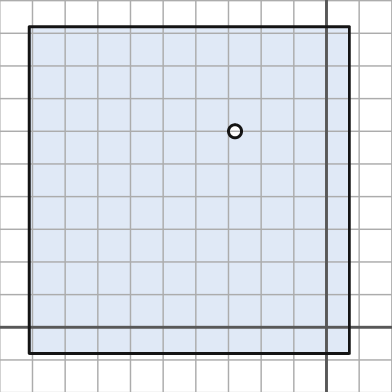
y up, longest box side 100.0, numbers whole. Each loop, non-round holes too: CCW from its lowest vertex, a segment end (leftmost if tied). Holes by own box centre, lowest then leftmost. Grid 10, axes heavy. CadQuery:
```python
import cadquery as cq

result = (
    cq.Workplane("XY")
    .moveTo(-91.0, -8.0)
    .lineTo(7.0, -8.0)
    .lineTo(7.0, 92.0)
    .lineTo(-91.0, 92.0)
    .close()
    .moveTo(-28.0, 60.0)
    .circle(2.0)
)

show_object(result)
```